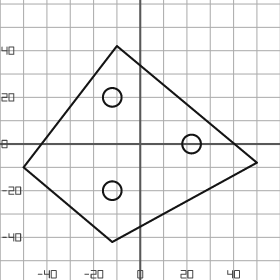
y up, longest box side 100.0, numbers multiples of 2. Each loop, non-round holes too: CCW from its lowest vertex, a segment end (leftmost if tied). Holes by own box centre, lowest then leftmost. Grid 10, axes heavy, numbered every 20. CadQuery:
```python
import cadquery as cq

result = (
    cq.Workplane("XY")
    .moveTo(-12.0, -42.0)
    .lineTo(50.0, -8.0)
    .lineTo(-10.0, 42.0)
    .lineTo(-50.0, -10.0)
    .close()
    .moveTo(-12.0, -20.0)
    .circle(4.0)
    .moveTo(22.0, 0.0)
    .circle(4.0)
    .moveTo(-12.0, 20.0)
    .circle(4.0)
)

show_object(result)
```